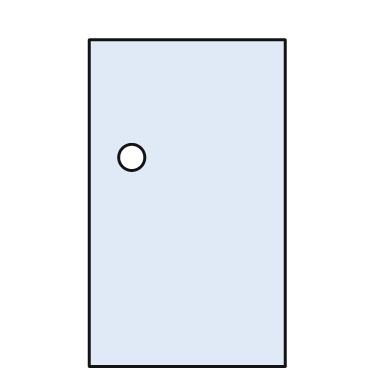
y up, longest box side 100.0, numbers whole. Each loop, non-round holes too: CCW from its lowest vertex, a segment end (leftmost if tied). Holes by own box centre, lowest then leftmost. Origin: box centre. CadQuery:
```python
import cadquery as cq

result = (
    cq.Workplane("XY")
    .moveTo(-30.0, -50.0)
    .lineTo(30.0, -50.0)
    .lineTo(30.0, 50.0)
    .lineTo(-30.0, 50.0)
    .close()
    .moveTo(-17.0, 14.0)
    .circle(4.0)
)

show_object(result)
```